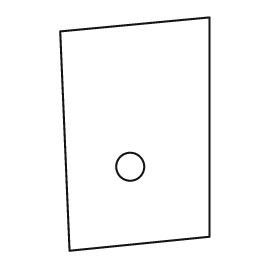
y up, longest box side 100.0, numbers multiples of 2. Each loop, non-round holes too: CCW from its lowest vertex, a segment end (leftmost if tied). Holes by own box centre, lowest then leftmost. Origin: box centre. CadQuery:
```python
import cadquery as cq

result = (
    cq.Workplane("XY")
    .moveTo(-28.0, -50.0)
    .lineTo(32.0, -44.0)
    .lineTo(32.0, 50.0)
    .lineTo(-32.0, 44.0)
    .close()
    .moveTo(-2.0, -14.0)
    .circle(6.0)
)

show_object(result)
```